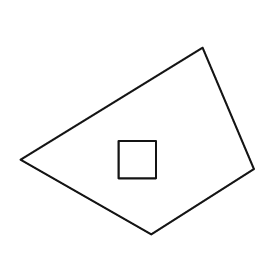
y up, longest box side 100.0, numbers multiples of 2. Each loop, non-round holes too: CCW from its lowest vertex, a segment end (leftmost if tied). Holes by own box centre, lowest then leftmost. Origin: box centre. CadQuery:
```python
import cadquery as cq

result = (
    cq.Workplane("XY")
    .moveTo(6.0, -40.0)
    .lineTo(50.0, -12.0)
    .lineTo(28.0, 40.0)
    .lineTo(-50.0, -8.0)
    .close()
    .moveTo(-8.0, -16.0)
    .lineTo(8.0, -16.0)
    .lineTo(8.0, 0.0)
    .lineTo(-8.0, 0.0)
    .close()
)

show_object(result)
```